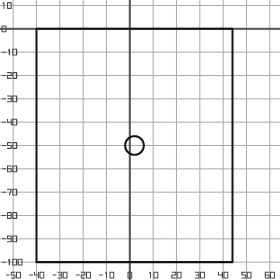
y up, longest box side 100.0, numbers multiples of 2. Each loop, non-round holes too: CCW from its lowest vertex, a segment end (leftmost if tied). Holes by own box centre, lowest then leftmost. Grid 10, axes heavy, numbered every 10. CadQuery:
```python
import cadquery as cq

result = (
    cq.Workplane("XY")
    .moveTo(-40.0, -100.0)
    .lineTo(44.0, -100.0)
    .lineTo(44.0, 0.0)
    .lineTo(-40.0, 0.0)
    .close()
    .moveTo(2.0, -50.0)
    .circle(4.0)
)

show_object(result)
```